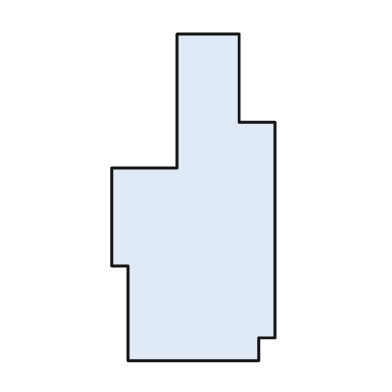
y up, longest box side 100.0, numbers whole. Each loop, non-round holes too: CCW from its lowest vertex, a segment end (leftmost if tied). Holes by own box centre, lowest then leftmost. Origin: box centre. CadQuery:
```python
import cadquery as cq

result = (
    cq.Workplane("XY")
    .moveTo(-20.0, -50.0)
    .lineTo(20.0, -50.0)
    .lineTo(20.0, -43.0)
    .lineTo(25.0, -43.0)
    .lineTo(25.0, 23.0)
    .lineTo(14.0, 23.0)
    .lineTo(14.0, 50.0)
    .lineTo(-5.0, 50.0)
    .lineTo(-5.0, 9.0)
    .lineTo(-25.0, 9.0)
    .lineTo(-25.0, -21.0)
    .lineTo(-20.0, -21.0)
    .close()
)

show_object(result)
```